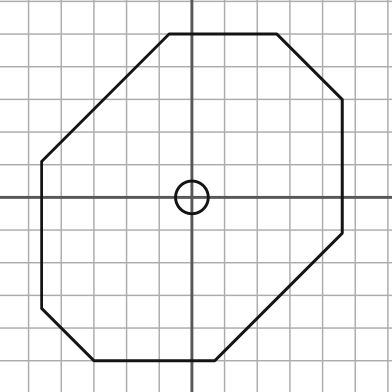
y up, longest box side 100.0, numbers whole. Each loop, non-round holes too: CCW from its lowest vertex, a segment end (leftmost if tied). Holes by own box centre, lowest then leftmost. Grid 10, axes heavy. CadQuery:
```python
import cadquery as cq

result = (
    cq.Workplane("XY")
    .moveTo(-30.0, -50.0)
    .lineTo(7.0, -50.0)
    .lineTo(46.0, -11.0)
    .lineTo(46.0, 30.0)
    .lineTo(26.0, 50.0)
    .lineTo(-7.0, 50.0)
    .lineTo(-46.0, 11.0)
    .lineTo(-46.0, -34.0)
    .close()
    .moveTo(0.0, 0.0)
    .circle(5.0)
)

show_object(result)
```